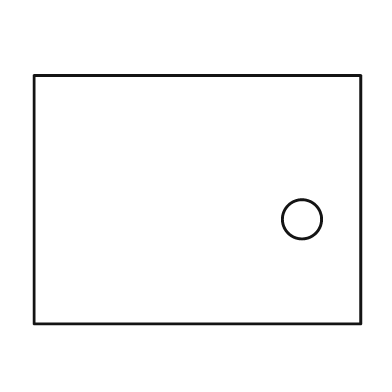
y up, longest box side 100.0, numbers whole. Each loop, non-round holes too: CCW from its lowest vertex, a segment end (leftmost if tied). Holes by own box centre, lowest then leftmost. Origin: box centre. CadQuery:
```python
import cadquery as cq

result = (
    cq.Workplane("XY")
    .moveTo(-50.0, -38.0)
    .lineTo(50.0, -38.0)
    .lineTo(50.0, 38.0)
    .lineTo(-50.0, 38.0)
    .close()
    .moveTo(32.0, -6.0)
    .circle(6.0)
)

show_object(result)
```